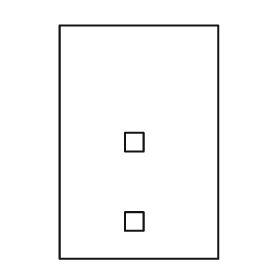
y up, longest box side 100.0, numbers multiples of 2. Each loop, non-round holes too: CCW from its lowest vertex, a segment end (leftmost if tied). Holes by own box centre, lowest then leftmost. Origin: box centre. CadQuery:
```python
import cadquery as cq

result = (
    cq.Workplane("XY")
    .moveTo(-34.0, -50.0)
    .lineTo(34.0, -50.0)
    .lineTo(34.0, 50.0)
    .lineTo(-34.0, 50.0)
    .close()
    .moveTo(-6.0, -38.0)
    .lineTo(2.0, -38.0)
    .lineTo(2.0, -30.0)
    .lineTo(-6.0, -30.0)
    .close()
    .moveTo(-6.0, -4.0)
    .lineTo(2.0, -4.0)
    .lineTo(2.0, 4.0)
    .lineTo(-6.0, 4.0)
    .close()
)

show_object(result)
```